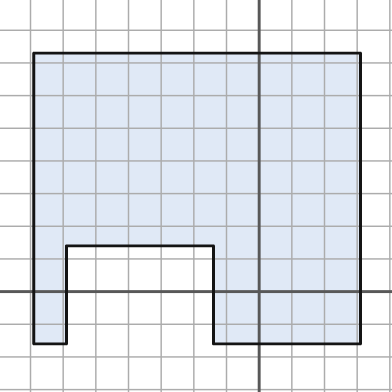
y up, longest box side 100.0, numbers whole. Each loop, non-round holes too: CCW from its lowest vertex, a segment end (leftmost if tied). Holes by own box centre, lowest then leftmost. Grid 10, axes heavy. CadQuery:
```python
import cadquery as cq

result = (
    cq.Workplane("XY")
    .moveTo(-69.0, -16.0)
    .lineTo(-59.0, -16.0)
    .lineTo(-59.0, 14.0)
    .lineTo(-14.0, 14.0)
    .lineTo(-14.0, -16.0)
    .lineTo(31.0, -16.0)
    .lineTo(31.0, 73.0)
    .lineTo(-69.0, 73.0)
    .close()
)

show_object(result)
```